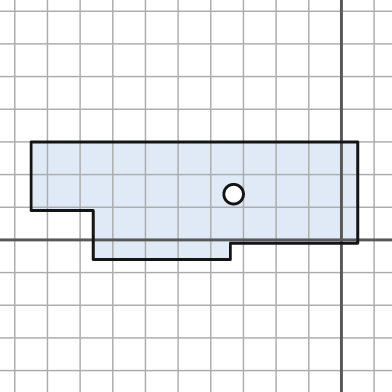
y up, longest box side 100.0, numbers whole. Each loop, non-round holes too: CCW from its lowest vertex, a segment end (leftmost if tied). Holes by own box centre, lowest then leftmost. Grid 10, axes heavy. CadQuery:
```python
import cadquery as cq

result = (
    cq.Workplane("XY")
    .moveTo(-76.0, -6.0)
    .lineTo(-34.0, -6.0)
    .lineTo(-34.0, -1.0)
    .lineTo(5.0, -1.0)
    .lineTo(5.0, 30.0)
    .lineTo(-95.0, 30.0)
    .lineTo(-95.0, 9.0)
    .lineTo(-76.0, 9.0)
    .close()
    .moveTo(-33.0, 14.0)
    .circle(3.0)
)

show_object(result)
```